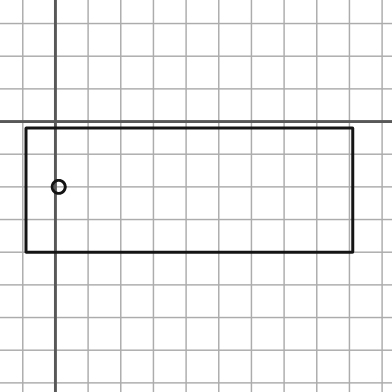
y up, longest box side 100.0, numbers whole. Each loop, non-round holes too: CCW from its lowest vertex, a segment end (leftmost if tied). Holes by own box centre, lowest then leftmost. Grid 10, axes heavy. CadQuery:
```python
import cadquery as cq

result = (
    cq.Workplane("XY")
    .moveTo(-9.0, -40.0)
    .lineTo(91.0, -40.0)
    .lineTo(91.0, -2.0)
    .lineTo(-9.0, -2.0)
    .close()
    .moveTo(1.0, -20.0)
    .circle(2.0)
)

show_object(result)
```